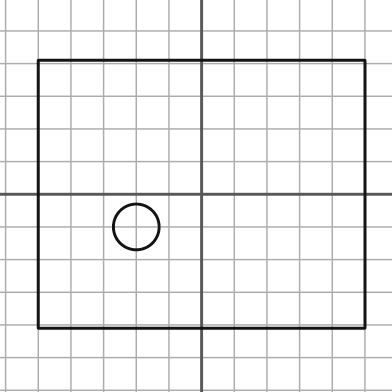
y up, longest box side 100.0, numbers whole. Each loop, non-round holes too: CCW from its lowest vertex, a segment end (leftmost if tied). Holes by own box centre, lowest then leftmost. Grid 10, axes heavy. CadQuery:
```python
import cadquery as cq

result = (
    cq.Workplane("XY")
    .moveTo(-50.0, -41.0)
    .lineTo(50.0, -41.0)
    .lineTo(50.0, 41.0)
    .lineTo(-50.0, 41.0)
    .close()
    .moveTo(-20.0, -10.0)
    .circle(7.0)
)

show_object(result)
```